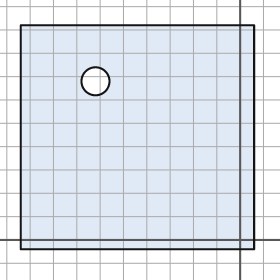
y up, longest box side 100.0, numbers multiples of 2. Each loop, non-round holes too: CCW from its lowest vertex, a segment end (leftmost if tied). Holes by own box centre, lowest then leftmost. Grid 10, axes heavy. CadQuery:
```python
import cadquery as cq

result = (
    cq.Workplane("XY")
    .moveTo(-94.0, -4.0)
    .lineTo(6.0, -4.0)
    .lineTo(6.0, 92.0)
    .lineTo(-94.0, 92.0)
    .close()
    .moveTo(-62.0, 68.0)
    .circle(6.0)
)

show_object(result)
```